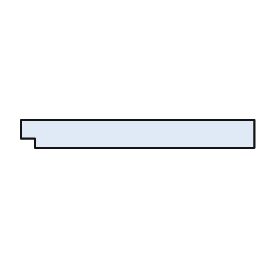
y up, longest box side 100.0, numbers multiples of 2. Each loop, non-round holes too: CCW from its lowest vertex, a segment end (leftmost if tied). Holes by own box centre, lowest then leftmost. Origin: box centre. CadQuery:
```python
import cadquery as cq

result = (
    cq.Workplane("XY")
    .moveTo(-44.0, -6.0)
    .lineTo(50.0, -6.0)
    .lineTo(50.0, 6.0)
    .lineTo(-50.0, 6.0)
    .lineTo(-50.0, -2.0)
    .lineTo(-44.0, -2.0)
    .close()
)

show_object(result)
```